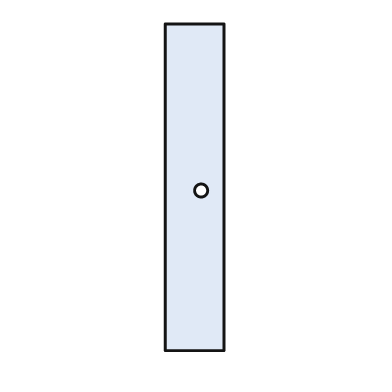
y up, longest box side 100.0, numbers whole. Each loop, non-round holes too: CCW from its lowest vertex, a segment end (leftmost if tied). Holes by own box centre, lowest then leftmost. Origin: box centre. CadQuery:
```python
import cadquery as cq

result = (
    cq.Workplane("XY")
    .moveTo(-9.0, -50.0)
    .lineTo(9.0, -50.0)
    .lineTo(9.0, 50.0)
    .lineTo(-9.0, 50.0)
    .close()
    .moveTo(2.0, -1.0)
    .circle(2.0)
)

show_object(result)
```